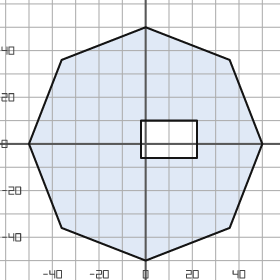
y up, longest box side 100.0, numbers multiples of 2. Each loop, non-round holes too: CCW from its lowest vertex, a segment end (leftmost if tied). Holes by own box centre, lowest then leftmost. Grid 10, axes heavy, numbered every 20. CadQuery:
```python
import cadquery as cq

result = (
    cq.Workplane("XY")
    .moveTo(0.0, -50.0)
    .lineTo(36.0, -36.0)
    .lineTo(50.0, 0.0)
    .lineTo(36.0, 36.0)
    .lineTo(0.0, 50.0)
    .lineTo(-36.0, 36.0)
    .lineTo(-50.0, 0.0)
    .lineTo(-36.0, -36.0)
    .close()
    .moveTo(-2.0, -6.0)
    .lineTo(22.0, -6.0)
    .lineTo(22.0, 10.0)
    .lineTo(-2.0, 10.0)
    .close()
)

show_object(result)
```